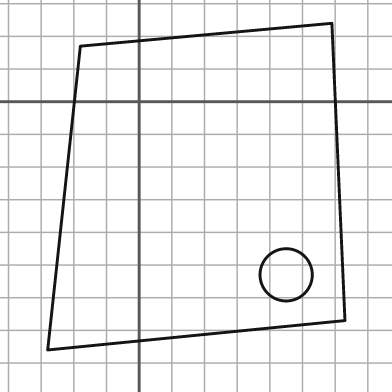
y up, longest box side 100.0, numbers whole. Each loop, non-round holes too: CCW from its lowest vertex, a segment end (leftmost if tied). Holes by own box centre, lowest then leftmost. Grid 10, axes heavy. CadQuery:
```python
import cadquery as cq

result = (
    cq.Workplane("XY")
    .moveTo(-28.0, -76.0)
    .lineTo(63.0, -67.0)
    .lineTo(59.0, 24.0)
    .lineTo(-18.0, 17.0)
    .close()
    .moveTo(45.0, -53.0)
    .circle(8.0)
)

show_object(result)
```